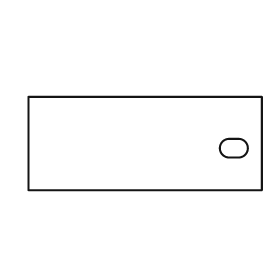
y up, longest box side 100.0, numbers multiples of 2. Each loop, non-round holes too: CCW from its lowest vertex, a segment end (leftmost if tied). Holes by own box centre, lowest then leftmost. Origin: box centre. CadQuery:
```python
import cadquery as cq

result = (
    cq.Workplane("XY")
    .moveTo(-50.0, -20.0)
    .lineTo(50.0, -20.0)
    .lineTo(50.0, 20.0)
    .lineTo(-50.0, 20.0)
    .close()
    .moveTo(36.0, -6.0)
    .lineTo(40.0, -6.0)
    .threePointArc((44.0, -2.0), (40.0, 2.0))
    .lineTo(36.0, 2.0)
    .threePointArc((32.0, -2.0), (36.0, -6.0))
    .close()
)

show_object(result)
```